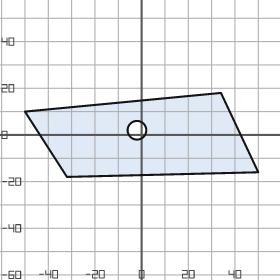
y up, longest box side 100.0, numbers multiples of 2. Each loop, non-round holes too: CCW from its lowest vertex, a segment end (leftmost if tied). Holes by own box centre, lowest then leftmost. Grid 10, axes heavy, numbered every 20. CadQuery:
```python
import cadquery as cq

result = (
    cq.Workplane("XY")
    .moveTo(-32.0, -18.0)
    .lineTo(50.0, -16.0)
    .lineTo(34.0, 18.0)
    .lineTo(-50.0, 10.0)
    .close()
    .moveTo(-2.0, 2.0)
    .circle(4.0)
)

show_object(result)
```